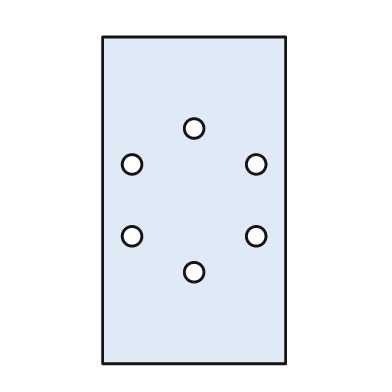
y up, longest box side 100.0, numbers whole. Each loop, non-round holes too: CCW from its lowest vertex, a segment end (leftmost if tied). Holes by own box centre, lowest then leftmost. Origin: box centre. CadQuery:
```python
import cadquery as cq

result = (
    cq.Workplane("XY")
    .moveTo(-28.0, -50.0)
    .lineTo(28.0, -50.0)
    .lineTo(28.0, 50.0)
    .lineTo(-28.0, 50.0)
    .close()
    .moveTo(0.0, -22.0)
    .circle(3.0)
    .moveTo(-19.0, -11.0)
    .circle(3.0)
    .moveTo(19.0, -11.0)
    .circle(3.0)
    .moveTo(-19.0, 11.0)
    .circle(3.0)
    .moveTo(19.0, 11.0)
    .circle(3.0)
    .moveTo(0.0, 22.0)
    .circle(3.0)
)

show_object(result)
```